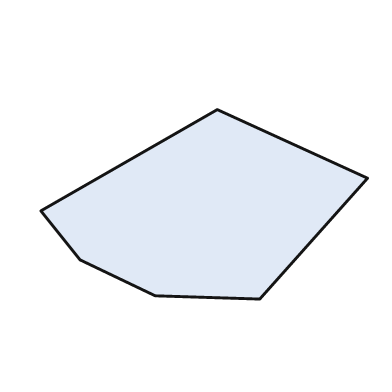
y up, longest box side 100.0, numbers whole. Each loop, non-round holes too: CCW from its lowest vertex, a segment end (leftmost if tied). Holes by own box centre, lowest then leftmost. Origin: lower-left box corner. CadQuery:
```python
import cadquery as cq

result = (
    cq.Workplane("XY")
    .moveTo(67.0, 0.0)
    .lineTo(100.0, 37.0)
    .lineTo(54.0, 58.0)
    .lineTo(0.0, 27.0)
    .lineTo(12.0, 12.0)
    .lineTo(35.0, 1.0)
    .close()
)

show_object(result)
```